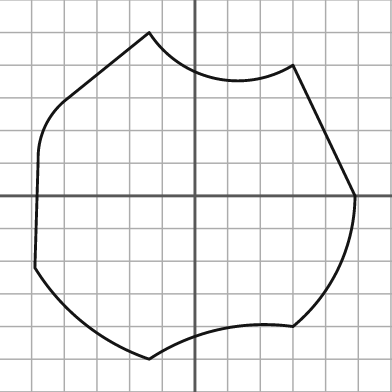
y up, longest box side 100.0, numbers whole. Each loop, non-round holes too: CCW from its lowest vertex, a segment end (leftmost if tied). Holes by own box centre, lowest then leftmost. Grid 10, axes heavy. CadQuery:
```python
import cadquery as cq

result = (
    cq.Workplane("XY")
    .moveTo(-14.0, -50.0)
    .threePointArc((7.0, -41.0), (30.0, -40.0))
    .threePointArc((44.0, -22.0), (49.0, 0.0))
    .lineTo(30.0, 40.0)
    .threePointArc((6.0, 36.0), (-14.0, 50.0))
    .lineTo(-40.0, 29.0)
    .threePointArc((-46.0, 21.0), (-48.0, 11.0))
    .lineTo(-49.0, -22.0)
    .threePointArc((-34.0, -39.0), (-14.0, -50.0))
    .close()
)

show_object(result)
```